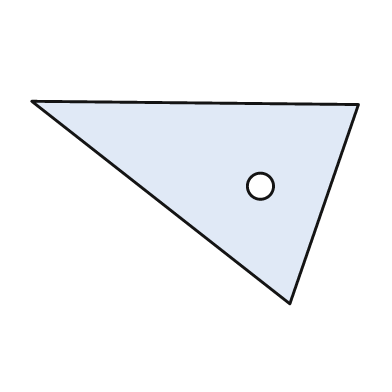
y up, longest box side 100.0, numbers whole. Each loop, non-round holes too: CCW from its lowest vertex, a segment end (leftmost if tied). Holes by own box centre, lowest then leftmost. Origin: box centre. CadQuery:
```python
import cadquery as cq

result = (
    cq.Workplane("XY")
    .moveTo(29.0, -31.0)
    .lineTo(50.0, 30.0)
    .lineTo(-50.0, 31.0)
    .close()
    .moveTo(20.0, 5.0)
    .circle(4.0)
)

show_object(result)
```